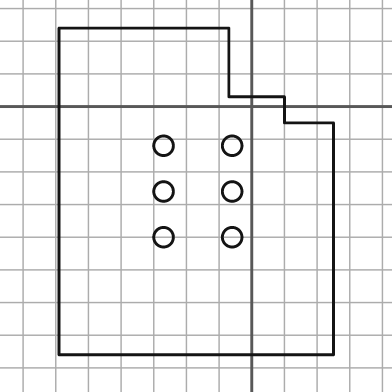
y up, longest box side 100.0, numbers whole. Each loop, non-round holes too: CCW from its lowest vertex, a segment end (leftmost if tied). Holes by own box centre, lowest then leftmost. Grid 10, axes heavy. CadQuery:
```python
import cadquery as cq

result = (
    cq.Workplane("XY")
    .moveTo(-59.0, -76.0)
    .lineTo(25.0, -76.0)
    .lineTo(25.0, -5.0)
    .lineTo(10.0, -5.0)
    .lineTo(10.0, 3.0)
    .lineTo(-7.0, 3.0)
    .lineTo(-7.0, 24.0)
    .lineTo(-59.0, 24.0)
    .close()
    .moveTo(-27.0, -40.0)
    .circle(3.0)
    .moveTo(-6.0, -40.0)
    .circle(3.0)
    .moveTo(-27.0, -26.0)
    .circle(3.0)
    .moveTo(-6.0, -26.0)
    .circle(3.0)
    .moveTo(-27.0, -12.0)
    .circle(3.0)
    .moveTo(-6.0, -12.0)
    .circle(3.0)
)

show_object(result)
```